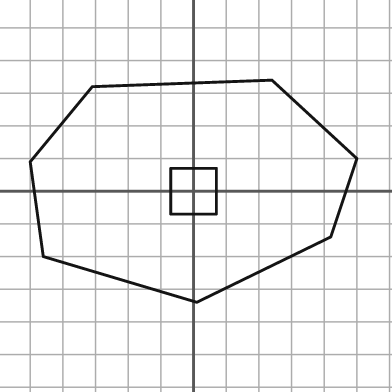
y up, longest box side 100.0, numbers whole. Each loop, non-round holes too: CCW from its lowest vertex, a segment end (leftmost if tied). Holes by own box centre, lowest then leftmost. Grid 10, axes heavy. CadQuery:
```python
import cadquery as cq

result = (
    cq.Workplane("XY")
    .moveTo(1.0, -34.0)
    .lineTo(42.0, -14.0)
    .lineTo(50.0, 10.0)
    .lineTo(24.0, 34.0)
    .lineTo(-31.0, 32.0)
    .lineTo(-50.0, 9.0)
    .lineTo(-46.0, -20.0)
    .close()
    .moveTo(-7.0, -7.0)
    .lineTo(7.0, -7.0)
    .lineTo(7.0, 7.0)
    .lineTo(-7.0, 7.0)
    .close()
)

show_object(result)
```